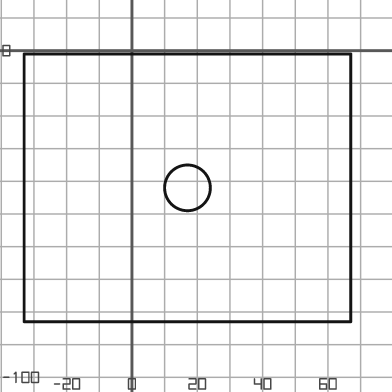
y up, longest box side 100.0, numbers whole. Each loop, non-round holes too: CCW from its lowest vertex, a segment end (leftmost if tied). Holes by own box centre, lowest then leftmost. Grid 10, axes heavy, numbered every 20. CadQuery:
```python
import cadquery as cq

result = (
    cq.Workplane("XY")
    .moveTo(-33.0, -83.0)
    .lineTo(67.0, -83.0)
    .lineTo(67.0, -1.0)
    .lineTo(-33.0, -1.0)
    .close()
    .moveTo(17.0, -42.0)
    .circle(7.0)
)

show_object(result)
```